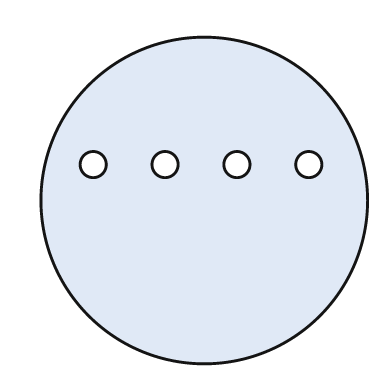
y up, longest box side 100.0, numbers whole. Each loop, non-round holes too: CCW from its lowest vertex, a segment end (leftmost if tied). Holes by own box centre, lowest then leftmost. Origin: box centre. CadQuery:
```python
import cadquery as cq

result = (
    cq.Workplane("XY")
    .moveTo(0.0, 0.0)
    .circle(50.0)
    .moveTo(-34.0, 11.0)
    .circle(4.0)
    .moveTo(-12.0, 11.0)
    .circle(4.0)
    .moveTo(10.0, 11.0)
    .circle(4.0)
    .moveTo(32.0, 11.0)
    .circle(4.0)
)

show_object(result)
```